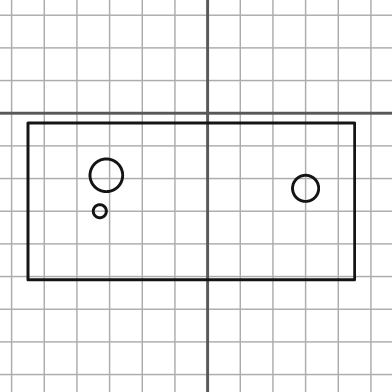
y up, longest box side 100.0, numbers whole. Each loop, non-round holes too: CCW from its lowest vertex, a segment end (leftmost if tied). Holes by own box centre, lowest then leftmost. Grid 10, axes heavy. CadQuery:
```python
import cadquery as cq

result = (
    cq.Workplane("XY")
    .moveTo(-55.0, -51.0)
    .lineTo(45.0, -51.0)
    .lineTo(45.0, -3.0)
    .lineTo(-55.0, -3.0)
    .close()
    .moveTo(-33.0, -30.0)
    .circle(2.0)
    .moveTo(30.0, -23.0)
    .circle(4.0)
    .moveTo(-31.0, -19.0)
    .circle(5.0)
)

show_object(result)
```